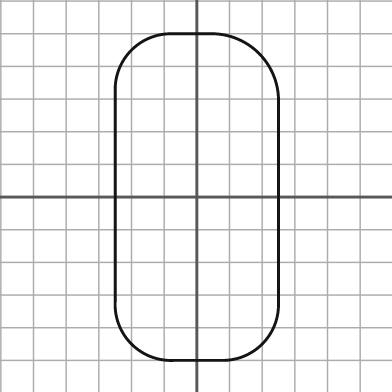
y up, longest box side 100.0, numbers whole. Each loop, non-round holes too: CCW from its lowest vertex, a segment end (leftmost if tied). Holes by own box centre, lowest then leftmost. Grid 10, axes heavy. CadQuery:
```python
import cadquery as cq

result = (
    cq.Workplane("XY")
    .moveTo(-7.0, -50.0)
    .lineTo(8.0, -50.0)
    .threePointArc((20.0, -45.0), (25.0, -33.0))
    .lineTo(25.0, 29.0)
    .threePointArc((19.0, 44.0), (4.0, 50.0))
    .lineTo(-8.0, 50.0)
    .threePointArc((-20.0, 45.0), (-25.0, 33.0))
    .lineTo(-25.0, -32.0)
    .threePointArc((-20.0, -45.0), (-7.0, -50.0))
    .close()
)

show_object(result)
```